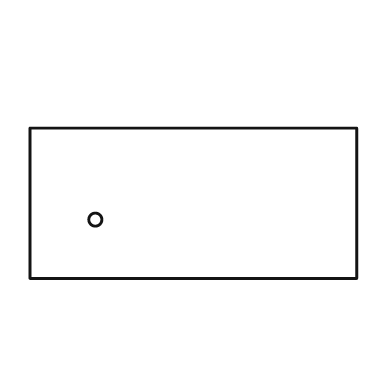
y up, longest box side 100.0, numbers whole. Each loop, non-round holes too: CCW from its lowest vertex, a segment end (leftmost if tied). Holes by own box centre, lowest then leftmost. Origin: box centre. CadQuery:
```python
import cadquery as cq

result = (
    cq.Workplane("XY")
    .moveTo(-50.0, -23.0)
    .lineTo(50.0, -23.0)
    .lineTo(50.0, 23.0)
    .lineTo(-50.0, 23.0)
    .close()
    .moveTo(-30.0, -5.0)
    .circle(2.0)
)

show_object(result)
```